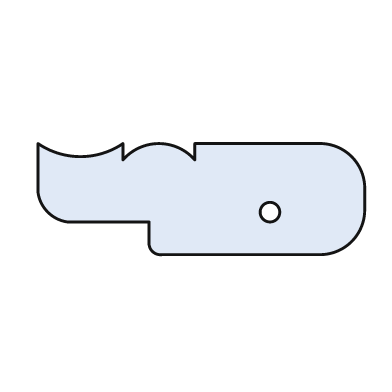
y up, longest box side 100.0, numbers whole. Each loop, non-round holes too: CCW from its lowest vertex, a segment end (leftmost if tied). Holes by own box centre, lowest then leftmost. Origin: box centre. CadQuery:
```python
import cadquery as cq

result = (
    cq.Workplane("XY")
    .moveTo(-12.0, -17.0)
    .lineTo(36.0, -17.0)
    .threePointArc((46.0, -13.0), (50.0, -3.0))
    .lineTo(50.0, 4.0)
    .threePointArc((46.0, 13.0), (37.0, 17.0))
    .lineTo(-2.0, 17.0)
    .lineTo(-2.0, 12.0)
    .threePointArc((-13.0, 17.0), (-24.0, 12.0))
    .lineTo(-24.0, 17.0)
    .threePointArc((-37.0, 13.0), (-50.0, 17.0))
    .lineTo(-50.0, 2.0)
    .threePointArc((-47.0, -4.0), (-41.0, -7.0))
    .lineTo(-16.0, -7.0)
    .lineTo(-16.0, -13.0)
    .threePointArc((-15.0, -16.0), (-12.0, -17.0))
    .close()
    .moveTo(21.0, -4.0)
    .circle(3.0)
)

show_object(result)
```